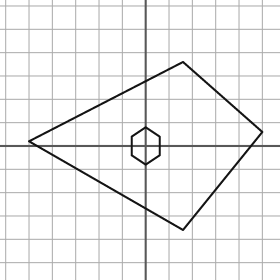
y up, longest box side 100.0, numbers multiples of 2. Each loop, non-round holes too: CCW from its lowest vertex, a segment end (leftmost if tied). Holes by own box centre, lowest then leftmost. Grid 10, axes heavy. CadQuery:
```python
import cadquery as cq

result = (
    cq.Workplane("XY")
    .moveTo(16.0, -36.0)
    .lineTo(50.0, 6.0)
    .lineTo(16.0, 36.0)
    .lineTo(-50.0, 2.0)
    .close()
    .moveTo(0.0, -8.0)
    .lineTo(6.0, -4.0)
    .lineTo(6.0, 4.0)
    .lineTo(0.0, 8.0)
    .lineTo(-6.0, 4.0)
    .lineTo(-6.0, -4.0)
    .close()
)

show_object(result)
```